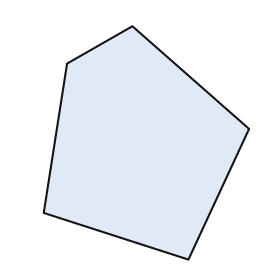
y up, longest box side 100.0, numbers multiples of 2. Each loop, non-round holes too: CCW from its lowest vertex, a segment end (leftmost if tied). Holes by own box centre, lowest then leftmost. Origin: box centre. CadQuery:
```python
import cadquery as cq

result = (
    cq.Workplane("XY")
    .moveTo(18.0, -50.0)
    .lineTo(44.0, 6.0)
    .lineTo(-6.0, 50.0)
    .lineTo(-34.0, 34.0)
    .lineTo(-44.0, -30.0)
    .close()
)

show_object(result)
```